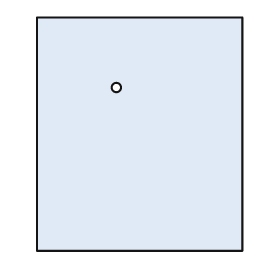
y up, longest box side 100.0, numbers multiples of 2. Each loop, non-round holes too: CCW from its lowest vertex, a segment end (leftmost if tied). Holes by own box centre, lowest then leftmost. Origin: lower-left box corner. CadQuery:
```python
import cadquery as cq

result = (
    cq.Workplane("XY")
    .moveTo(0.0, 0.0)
    .lineTo(88.0, 0.0)
    .lineTo(88.0, 100.0)
    .lineTo(0.0, 100.0)
    .close()
    .moveTo(34.0, 70.0)
    .circle(2.0)
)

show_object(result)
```